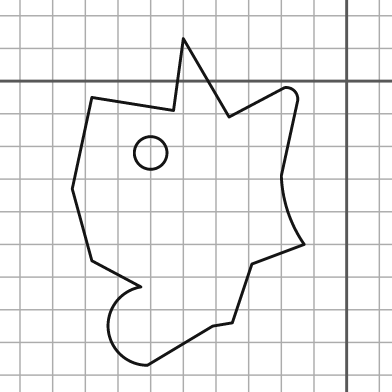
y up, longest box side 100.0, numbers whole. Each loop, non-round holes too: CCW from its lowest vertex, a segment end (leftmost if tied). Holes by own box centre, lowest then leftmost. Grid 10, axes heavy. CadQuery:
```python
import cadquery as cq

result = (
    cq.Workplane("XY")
    .moveTo(-61.0, -87.0)
    .lineTo(-41.0, -75.0)
    .lineTo(-35.0, -74.0)
    .lineTo(-29.0, -56.0)
    .lineTo(-13.0, -50.0)
    .threePointArc((-18.0, -40.0), (-20.0, -29.0))
    .lineTo(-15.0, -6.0)
    .threePointArc((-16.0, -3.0), (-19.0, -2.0))
    .lineTo(-36.0, -11.0)
    .lineTo(-50.0, 13.0)
    .lineTo(-53.0, -9.0)
    .lineTo(-78.0, -5.0)
    .lineTo(-84.0, -33.0)
    .lineTo(-78.0, -55.0)
    .lineTo(-63.0, -63.0)
    .threePointArc((-73.0, -76.0), (-61.0, -87.0))
    .close()
    .moveTo(-60.0, -22.0)
    .circle(5.0)
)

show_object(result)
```